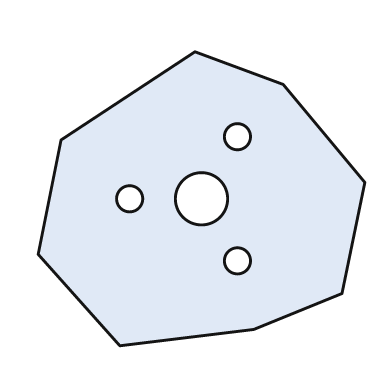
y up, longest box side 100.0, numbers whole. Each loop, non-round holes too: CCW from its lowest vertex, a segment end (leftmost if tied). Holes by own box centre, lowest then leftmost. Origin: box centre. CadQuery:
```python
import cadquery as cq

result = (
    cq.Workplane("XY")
    .moveTo(-25.0, -45.0)
    .lineTo(16.0, -40.0)
    .lineTo(43.0, -29.0)
    .lineTo(50.0, 5.0)
    .lineTo(25.0, 35.0)
    .lineTo(-2.0, 45.0)
    .lineTo(-43.0, 18.0)
    .lineTo(-50.0, -17.0)
    .close()
    .moveTo(11.0, -19.0)
    .circle(4.0)
    .moveTo(-22.0, 0.0)
    .circle(4.0)
    .moveTo(0.0, 0.0)
    .circle(8.0)
    .moveTo(11.0, 19.0)
    .circle(4.0)
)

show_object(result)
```